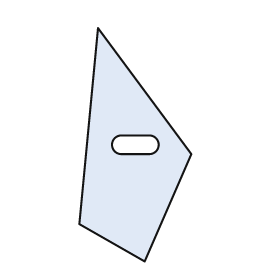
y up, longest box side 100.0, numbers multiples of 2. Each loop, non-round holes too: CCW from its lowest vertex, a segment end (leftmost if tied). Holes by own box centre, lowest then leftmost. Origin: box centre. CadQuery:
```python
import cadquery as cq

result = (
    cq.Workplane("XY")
    .moveTo(4.0, -50.0)
    .lineTo(24.0, -4.0)
    .lineTo(-16.0, 50.0)
    .lineTo(-24.0, -34.0)
    .close()
    .moveTo(-6.0, -4.0)
    .lineTo(6.0, -4.0)
    .threePointArc((10.0, 0.0), (6.0, 4.0))
    .lineTo(-6.0, 4.0)
    .threePointArc((-10.0, 0.0), (-6.0, -4.0))
    .close()
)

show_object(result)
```